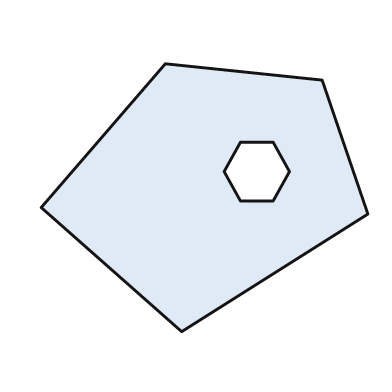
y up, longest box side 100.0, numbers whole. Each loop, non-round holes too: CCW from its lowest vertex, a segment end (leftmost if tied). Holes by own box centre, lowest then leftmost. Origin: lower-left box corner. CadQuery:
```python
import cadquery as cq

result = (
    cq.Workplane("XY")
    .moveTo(43.0, 0.0)
    .lineTo(100.0, 36.0)
    .lineTo(86.0, 77.0)
    .lineTo(38.0, 82.0)
    .lineTo(0.0, 38.0)
    .close()
    .moveTo(61.0, 40.0)
    .lineTo(71.0, 40.0)
    .lineTo(76.0, 49.0)
    .lineTo(71.0, 58.0)
    .lineTo(61.0, 58.0)
    .lineTo(56.0, 49.0)
    .close()
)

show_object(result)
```